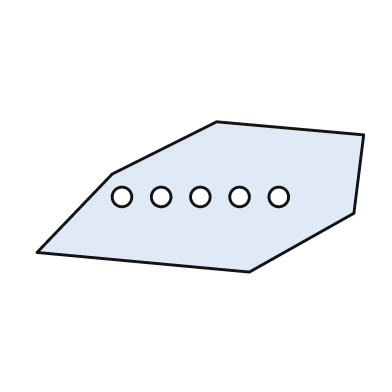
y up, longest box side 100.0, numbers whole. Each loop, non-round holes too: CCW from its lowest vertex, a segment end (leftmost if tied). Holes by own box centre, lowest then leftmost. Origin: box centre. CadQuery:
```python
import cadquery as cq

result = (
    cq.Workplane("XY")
    .moveTo(15.0, -23.0)
    .lineTo(47.0, -5.0)
    .lineTo(50.0, 19.0)
    .lineTo(5.0, 23.0)
    .lineTo(-27.0, 7.0)
    .lineTo(-50.0, -17.0)
    .close()
    .moveTo(-24.0, 0.0)
    .circle(3.0)
    .moveTo(-12.0, 0.0)
    .circle(3.0)
    .moveTo(0.0, 0.0)
    .circle(3.0)
    .moveTo(12.0, 0.0)
    .circle(3.0)
    .moveTo(24.0, 0.0)
    .circle(3.0)
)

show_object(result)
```